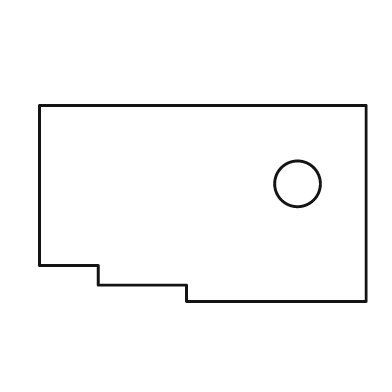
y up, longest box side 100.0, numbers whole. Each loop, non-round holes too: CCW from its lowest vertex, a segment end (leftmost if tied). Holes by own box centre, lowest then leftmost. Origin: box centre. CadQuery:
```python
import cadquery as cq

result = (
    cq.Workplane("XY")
    .moveTo(-5.0, -30.0)
    .lineTo(50.0, -30.0)
    .lineTo(50.0, 30.0)
    .lineTo(-50.0, 30.0)
    .lineTo(-50.0, -19.0)
    .lineTo(-32.0, -19.0)
    .lineTo(-32.0, -25.0)
    .lineTo(-5.0, -25.0)
    .close()
    .moveTo(29.0, 6.0)
    .circle(7.0)
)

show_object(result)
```